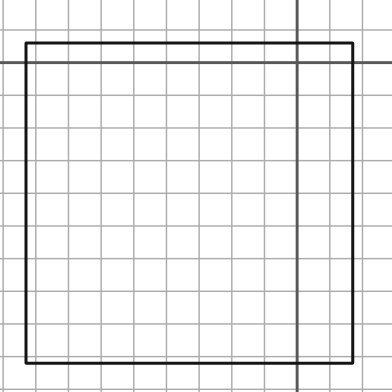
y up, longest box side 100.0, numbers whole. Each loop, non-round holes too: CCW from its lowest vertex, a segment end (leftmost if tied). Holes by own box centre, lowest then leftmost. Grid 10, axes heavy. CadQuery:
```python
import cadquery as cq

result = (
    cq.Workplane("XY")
    .moveTo(-83.0, -92.0)
    .lineTo(17.0, -92.0)
    .lineTo(17.0, 6.0)
    .lineTo(-83.0, 6.0)
    .close()
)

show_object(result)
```